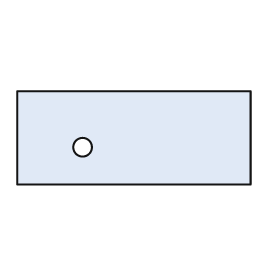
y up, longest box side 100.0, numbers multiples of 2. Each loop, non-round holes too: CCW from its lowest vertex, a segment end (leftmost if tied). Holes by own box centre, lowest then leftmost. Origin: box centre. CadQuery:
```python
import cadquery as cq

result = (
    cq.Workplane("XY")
    .moveTo(-50.0, -20.0)
    .lineTo(50.0, -20.0)
    .lineTo(50.0, 20.0)
    .lineTo(-50.0, 20.0)
    .close()
    .moveTo(-22.0, -4.0)
    .circle(4.0)
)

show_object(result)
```